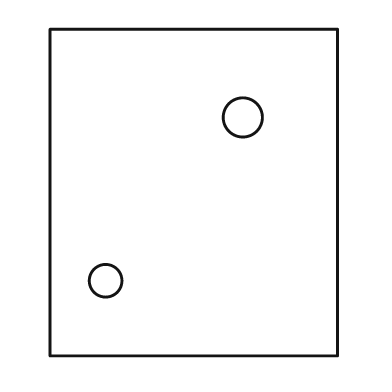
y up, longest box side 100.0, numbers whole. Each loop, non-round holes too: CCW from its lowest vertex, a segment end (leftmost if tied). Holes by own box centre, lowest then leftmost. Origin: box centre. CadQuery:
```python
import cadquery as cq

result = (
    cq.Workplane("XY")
    .moveTo(-44.0, -50.0)
    .lineTo(44.0, -50.0)
    .lineTo(44.0, 50.0)
    .lineTo(-44.0, 50.0)
    .close()
    .moveTo(-27.0, -27.0)
    .circle(5.0)
    .moveTo(15.0, 23.0)
    .circle(6.0)
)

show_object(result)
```